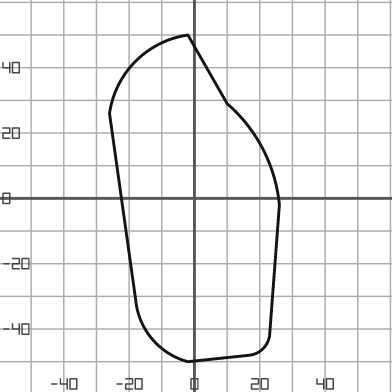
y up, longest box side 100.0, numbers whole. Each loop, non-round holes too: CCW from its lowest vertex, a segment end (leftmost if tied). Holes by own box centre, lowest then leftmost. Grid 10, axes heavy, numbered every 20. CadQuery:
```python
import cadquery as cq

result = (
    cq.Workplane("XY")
    .moveTo(-2.0, -50.0)
    .lineTo(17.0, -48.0)
    .threePointArc((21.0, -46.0), (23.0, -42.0))
    .lineTo(26.0, -2.0)
    .threePointArc((21.0, 15.0), (10.0, 29.0))
    .lineTo(-2.0, 50.0)
    .threePointArc((-18.0, 42.0), (-26.0, 26.0))
    .lineTo(-18.0, -31.0)
    .threePointArc((-13.0, -43.0), (-2.0, -50.0))
    .close()
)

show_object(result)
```